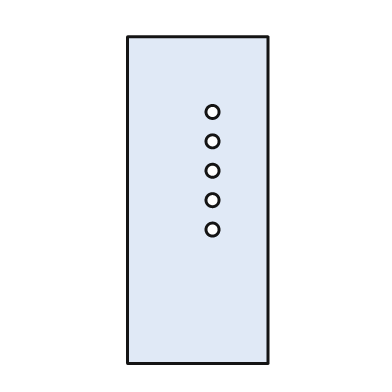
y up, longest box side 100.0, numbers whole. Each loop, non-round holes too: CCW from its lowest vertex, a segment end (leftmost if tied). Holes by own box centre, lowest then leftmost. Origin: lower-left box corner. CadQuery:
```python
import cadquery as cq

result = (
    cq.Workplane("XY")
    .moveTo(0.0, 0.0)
    .lineTo(43.0, 0.0)
    .lineTo(43.0, 100.0)
    .lineTo(0.0, 100.0)
    .close()
    .moveTo(26.0, 41.0)
    .circle(2.0)
    .moveTo(26.0, 50.0)
    .circle(2.0)
    .moveTo(26.0, 59.0)
    .circle(2.0)
    .moveTo(26.0, 68.0)
    .circle(2.0)
    .moveTo(26.0, 77.0)
    .circle(2.0)
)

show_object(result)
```